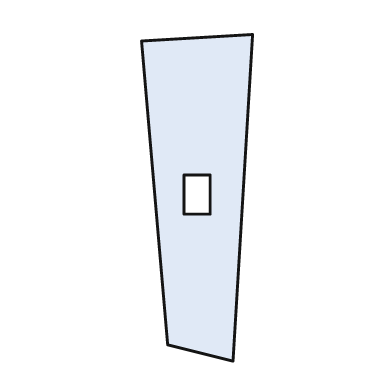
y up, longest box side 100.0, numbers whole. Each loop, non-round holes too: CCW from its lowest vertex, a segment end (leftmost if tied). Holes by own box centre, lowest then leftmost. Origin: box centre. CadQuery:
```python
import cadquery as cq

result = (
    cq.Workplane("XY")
    .moveTo(11.0, -50.0)
    .lineTo(17.0, 50.0)
    .lineTo(-17.0, 48.0)
    .lineTo(-9.0, -45.0)
    .close()
    .moveTo(-4.0, -5.0)
    .lineTo(4.0, -5.0)
    .lineTo(4.0, 7.0)
    .lineTo(-4.0, 7.0)
    .close()
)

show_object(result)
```